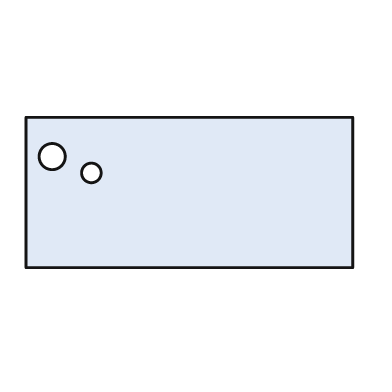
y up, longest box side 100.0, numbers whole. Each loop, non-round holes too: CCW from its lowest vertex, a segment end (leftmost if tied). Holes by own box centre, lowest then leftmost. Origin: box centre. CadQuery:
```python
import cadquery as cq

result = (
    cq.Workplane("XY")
    .moveTo(-50.0, -23.0)
    .lineTo(50.0, -23.0)
    .lineTo(50.0, 23.0)
    .lineTo(-50.0, 23.0)
    .close()
    .moveTo(-30.0, 6.0)
    .circle(3.0)
    .moveTo(-42.0, 11.0)
    .circle(4.0)
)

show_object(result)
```